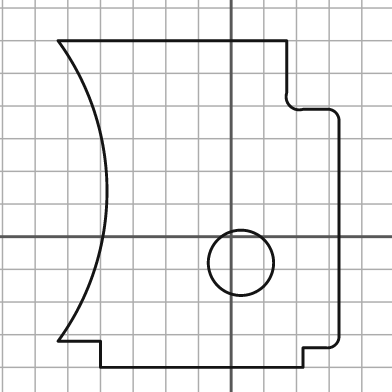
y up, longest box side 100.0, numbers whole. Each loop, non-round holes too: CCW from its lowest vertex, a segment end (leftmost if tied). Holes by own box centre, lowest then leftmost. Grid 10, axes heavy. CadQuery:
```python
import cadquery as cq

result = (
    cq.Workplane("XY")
    .moveTo(-40.0, -40.0)
    .lineTo(22.0, -40.0)
    .lineTo(22.0, -34.0)
    .lineTo(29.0, -34.0)
    .threePointArc((32.0, -33.0), (33.0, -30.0))
    .lineTo(33.0, 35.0)
    .threePointArc((32.0, 38.0), (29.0, 39.0))
    .lineTo(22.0, 39.0)
    .threePointArc((18.0, 40.0), (17.0, 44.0))
    .lineTo(17.0, 60.0)
    .lineTo(-53.0, 60.0)
    .threePointArc((-38.0, 14.0), (-53.0, -32.0))
    .lineTo(-40.0, -32.0)
    .close()
    .moveTo(3.0, -8.0)
    .circle(10.0)
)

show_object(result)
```